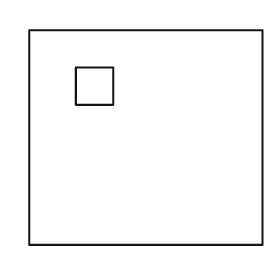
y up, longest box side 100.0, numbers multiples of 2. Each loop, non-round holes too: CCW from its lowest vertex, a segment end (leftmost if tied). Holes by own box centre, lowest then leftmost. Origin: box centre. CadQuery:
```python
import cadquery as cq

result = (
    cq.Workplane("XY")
    .moveTo(-50.0, -46.0)
    .lineTo(50.0, -46.0)
    .lineTo(50.0, 46.0)
    .lineTo(-50.0, 46.0)
    .close()
    .moveTo(-30.0, 14.0)
    .lineTo(-14.0, 14.0)
    .lineTo(-14.0, 30.0)
    .lineTo(-30.0, 30.0)
    .close()
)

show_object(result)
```